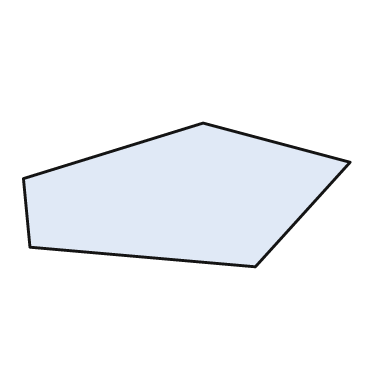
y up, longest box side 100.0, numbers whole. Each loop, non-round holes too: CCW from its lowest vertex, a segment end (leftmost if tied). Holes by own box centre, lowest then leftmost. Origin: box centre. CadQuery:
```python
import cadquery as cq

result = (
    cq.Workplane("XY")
    .moveTo(21.0, -22.0)
    .lineTo(50.0, 10.0)
    .lineTo(5.0, 22.0)
    .lineTo(-50.0, 5.0)
    .lineTo(-48.0, -16.0)
    .close()
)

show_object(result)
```